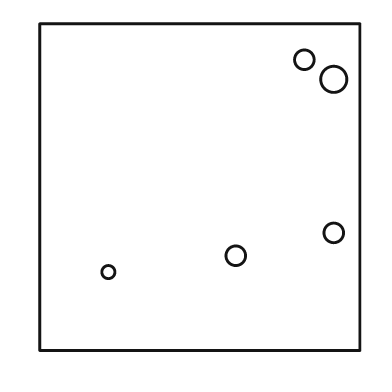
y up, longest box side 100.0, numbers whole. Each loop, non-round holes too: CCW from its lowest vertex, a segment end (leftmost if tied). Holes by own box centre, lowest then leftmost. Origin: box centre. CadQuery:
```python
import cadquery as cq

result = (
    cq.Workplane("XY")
    .moveTo(-49.0, -50.0)
    .lineTo(49.0, -50.0)
    .lineTo(49.0, 50.0)
    .lineTo(-49.0, 50.0)
    .close()
    .moveTo(-28.0, -26.0)
    .circle(2.0)
    .moveTo(11.0, -21.0)
    .circle(3.0)
    .moveTo(41.0, -14.0)
    .circle(3.0)
    .moveTo(41.0, 33.0)
    .circle(4.0)
    .moveTo(32.0, 39.0)
    .circle(3.0)
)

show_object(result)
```